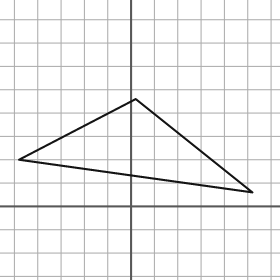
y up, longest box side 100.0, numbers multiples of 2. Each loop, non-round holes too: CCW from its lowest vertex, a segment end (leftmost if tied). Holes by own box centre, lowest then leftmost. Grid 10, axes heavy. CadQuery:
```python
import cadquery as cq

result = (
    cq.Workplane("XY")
    .moveTo(52.0, 6.0)
    .lineTo(2.0, 46.0)
    .lineTo(-48.0, 20.0)
    .close()
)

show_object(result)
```